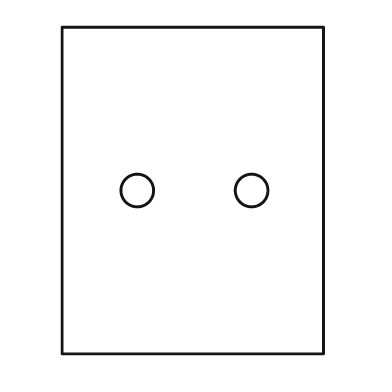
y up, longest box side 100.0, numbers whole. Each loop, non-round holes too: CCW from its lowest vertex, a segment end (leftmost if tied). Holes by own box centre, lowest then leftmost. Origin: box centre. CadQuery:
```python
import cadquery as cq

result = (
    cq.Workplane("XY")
    .moveTo(-40.0, -50.0)
    .lineTo(40.0, -50.0)
    .lineTo(40.0, 50.0)
    .lineTo(-40.0, 50.0)
    .close()
    .moveTo(-17.0, 0.0)
    .circle(5.0)
    .moveTo(18.0, 0.0)
    .circle(5.0)
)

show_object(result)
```